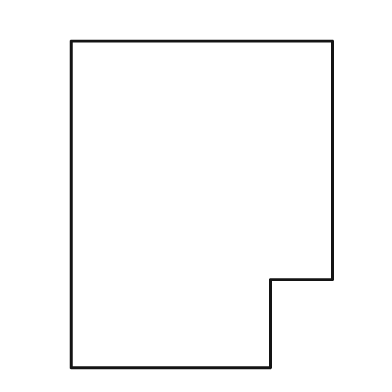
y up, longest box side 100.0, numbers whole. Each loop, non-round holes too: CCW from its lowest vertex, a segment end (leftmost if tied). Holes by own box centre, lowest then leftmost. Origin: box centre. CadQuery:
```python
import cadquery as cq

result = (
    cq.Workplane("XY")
    .moveTo(-40.0, -50.0)
    .lineTo(21.0, -50.0)
    .lineTo(21.0, -23.0)
    .lineTo(40.0, -23.0)
    .lineTo(40.0, 50.0)
    .lineTo(-40.0, 50.0)
    .close()
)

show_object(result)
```